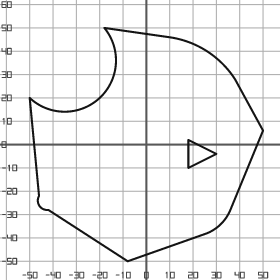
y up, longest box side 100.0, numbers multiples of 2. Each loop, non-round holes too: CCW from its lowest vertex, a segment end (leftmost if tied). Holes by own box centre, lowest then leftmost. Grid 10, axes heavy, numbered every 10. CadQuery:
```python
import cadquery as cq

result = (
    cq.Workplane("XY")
    .moveTo(-8.0, -50.0)
    .lineTo(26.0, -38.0)
    .threePointArc((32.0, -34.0), (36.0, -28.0))
    .lineTo(50.0, 6.0)
    .lineTo(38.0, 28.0)
    .threePointArc((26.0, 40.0), (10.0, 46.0))
    .lineTo(-18.0, 50.0)
    .threePointArc((-20.0, 20.0), (-50.0, 20.0))
    .lineTo(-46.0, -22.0)
    .threePointArc((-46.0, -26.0), (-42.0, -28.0))
    .close()
    .moveTo(18.0, -10.0)
    .lineTo(30.0, -4.0)
    .lineTo(18.0, 2.0)
    .close()
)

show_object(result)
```